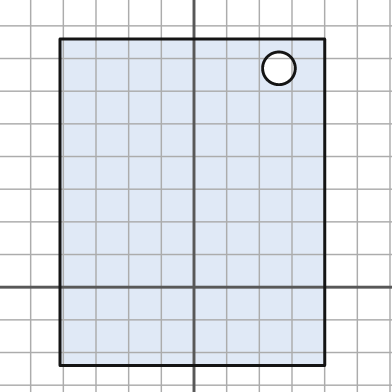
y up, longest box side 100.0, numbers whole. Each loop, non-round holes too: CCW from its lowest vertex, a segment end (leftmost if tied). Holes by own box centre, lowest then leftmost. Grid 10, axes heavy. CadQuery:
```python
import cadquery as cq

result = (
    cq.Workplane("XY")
    .moveTo(-41.0, -24.0)
    .lineTo(40.0, -24.0)
    .lineTo(40.0, 76.0)
    .lineTo(-41.0, 76.0)
    .close()
    .moveTo(26.0, 67.0)
    .circle(5.0)
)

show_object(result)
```